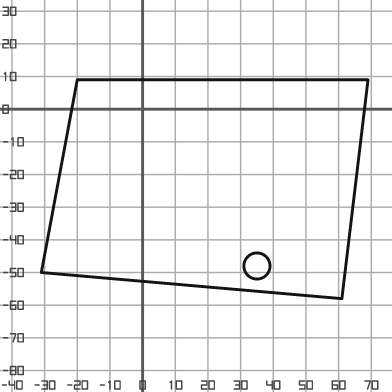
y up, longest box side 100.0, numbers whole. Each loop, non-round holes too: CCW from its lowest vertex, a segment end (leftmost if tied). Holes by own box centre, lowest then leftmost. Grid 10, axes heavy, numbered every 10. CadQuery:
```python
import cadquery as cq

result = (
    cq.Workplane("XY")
    .moveTo(61.0, -58.0)
    .lineTo(69.0, 9.0)
    .lineTo(-20.0, 9.0)
    .lineTo(-31.0, -50.0)
    .close()
    .moveTo(35.0, -48.0)
    .circle(4.0)
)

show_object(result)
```